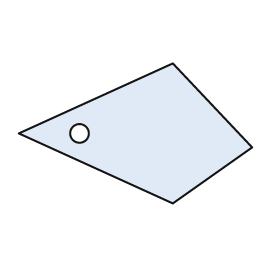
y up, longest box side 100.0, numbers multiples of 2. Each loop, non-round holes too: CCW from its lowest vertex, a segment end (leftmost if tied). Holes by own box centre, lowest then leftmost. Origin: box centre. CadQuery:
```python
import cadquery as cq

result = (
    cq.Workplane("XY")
    .moveTo(16.0, -30.0)
    .lineTo(50.0, -6.0)
    .lineTo(16.0, 30.0)
    .lineTo(-50.0, 0.0)
    .close()
    .moveTo(-24.0, 0.0)
    .circle(4.0)
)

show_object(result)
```